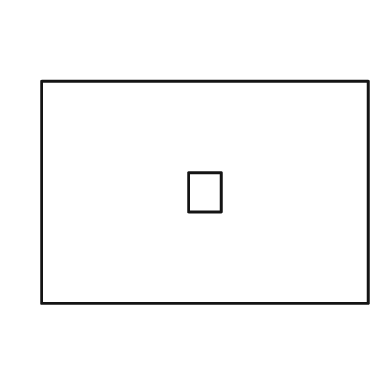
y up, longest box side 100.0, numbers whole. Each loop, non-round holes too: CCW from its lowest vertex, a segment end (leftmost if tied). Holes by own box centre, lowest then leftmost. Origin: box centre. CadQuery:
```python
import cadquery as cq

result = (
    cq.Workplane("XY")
    .moveTo(-50.0, -34.0)
    .lineTo(50.0, -34.0)
    .lineTo(50.0, 34.0)
    .lineTo(-50.0, 34.0)
    .close()
    .moveTo(-5.0, -6.0)
    .lineTo(5.0, -6.0)
    .lineTo(5.0, 6.0)
    .lineTo(-5.0, 6.0)
    .close()
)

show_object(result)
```